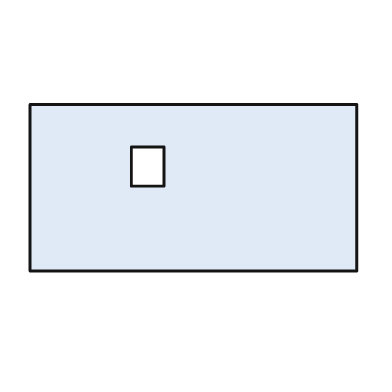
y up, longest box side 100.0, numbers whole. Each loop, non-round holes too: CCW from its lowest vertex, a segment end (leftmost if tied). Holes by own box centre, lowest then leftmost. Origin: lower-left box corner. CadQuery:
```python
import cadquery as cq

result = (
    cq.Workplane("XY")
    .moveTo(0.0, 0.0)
    .lineTo(100.0, 0.0)
    .lineTo(100.0, 51.0)
    .lineTo(0.0, 51.0)
    .close()
    .moveTo(31.0, 26.0)
    .lineTo(41.0, 26.0)
    .lineTo(41.0, 38.0)
    .lineTo(31.0, 38.0)
    .close()
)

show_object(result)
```